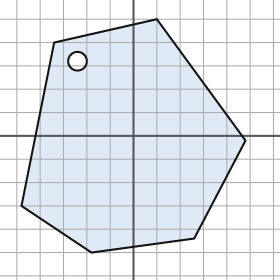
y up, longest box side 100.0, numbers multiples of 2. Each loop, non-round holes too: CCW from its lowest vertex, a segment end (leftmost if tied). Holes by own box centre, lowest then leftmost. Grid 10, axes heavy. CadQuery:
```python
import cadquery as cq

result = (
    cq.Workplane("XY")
    .moveTo(-18.0, -50.0)
    .lineTo(26.0, -44.0)
    .lineTo(48.0, -2.0)
    .lineTo(10.0, 50.0)
    .lineTo(-34.0, 40.0)
    .lineTo(-48.0, -30.0)
    .close()
    .moveTo(-24.0, 32.0)
    .circle(4.0)
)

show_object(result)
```